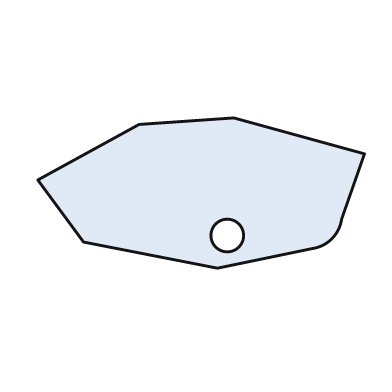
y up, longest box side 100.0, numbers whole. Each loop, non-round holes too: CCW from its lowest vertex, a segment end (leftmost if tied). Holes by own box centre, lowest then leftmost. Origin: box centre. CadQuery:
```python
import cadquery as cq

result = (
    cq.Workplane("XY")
    .moveTo(5.0, -23.0)
    .lineTo(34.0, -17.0)
    .threePointArc((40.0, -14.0), (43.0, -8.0))
    .lineTo(50.0, 12.0)
    .lineTo(10.0, 23.0)
    .lineTo(-19.0, 21.0)
    .lineTo(-50.0, 4.0)
    .lineTo(-36.0, -15.0)
    .close()
    .moveTo(8.0, -13.0)
    .circle(5.0)
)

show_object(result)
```